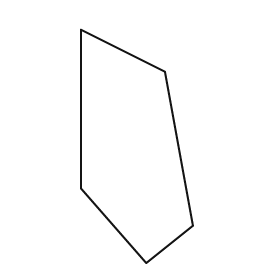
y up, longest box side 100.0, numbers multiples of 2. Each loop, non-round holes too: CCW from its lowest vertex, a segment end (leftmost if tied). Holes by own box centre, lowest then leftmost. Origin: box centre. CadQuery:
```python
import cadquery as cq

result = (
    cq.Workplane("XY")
    .moveTo(4.0, -50.0)
    .lineTo(24.0, -34.0)
    .lineTo(12.0, 32.0)
    .lineTo(-24.0, 50.0)
    .lineTo(-24.0, -18.0)
    .close()
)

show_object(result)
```